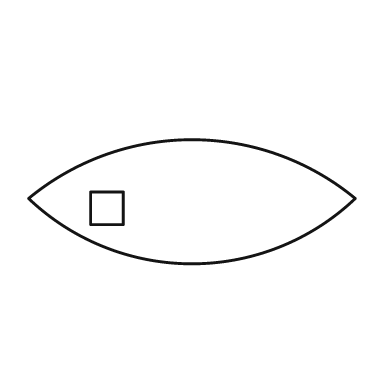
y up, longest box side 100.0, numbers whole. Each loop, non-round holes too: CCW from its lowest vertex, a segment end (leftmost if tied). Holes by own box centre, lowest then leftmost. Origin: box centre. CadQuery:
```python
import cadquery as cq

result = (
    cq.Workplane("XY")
    .moveTo(-50.0, 1.0)
    .threePointArc((0.0, -19.0), (50.0, 1.0))
    .threePointArc((0.0, 19.0), (-50.0, 1.0))
    .close()
    .moveTo(-31.0, -7.0)
    .lineTo(-21.0, -7.0)
    .lineTo(-21.0, 3.0)
    .lineTo(-31.0, 3.0)
    .close()
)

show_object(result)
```